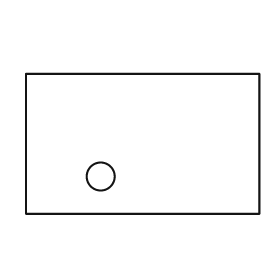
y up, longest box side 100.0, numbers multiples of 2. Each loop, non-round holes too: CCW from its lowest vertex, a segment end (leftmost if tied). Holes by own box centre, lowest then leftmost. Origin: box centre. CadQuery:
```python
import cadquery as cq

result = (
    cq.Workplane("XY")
    .moveTo(-50.0, -30.0)
    .lineTo(50.0, -30.0)
    .lineTo(50.0, 30.0)
    .lineTo(-50.0, 30.0)
    .close()
    .moveTo(-18.0, -14.0)
    .circle(6.0)
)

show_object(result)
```